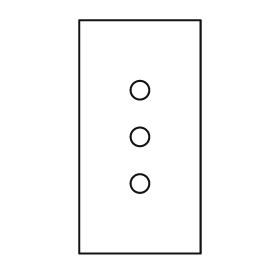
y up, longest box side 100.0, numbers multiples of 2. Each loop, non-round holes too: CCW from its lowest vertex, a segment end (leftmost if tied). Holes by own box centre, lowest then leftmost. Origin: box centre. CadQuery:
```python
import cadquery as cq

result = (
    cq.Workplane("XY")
    .moveTo(-26.0, -50.0)
    .lineTo(26.0, -50.0)
    .lineTo(26.0, 50.0)
    .lineTo(-26.0, 50.0)
    .close()
    .moveTo(0.0, -20.0)
    .circle(4.0)
    .moveTo(0.0, 0.0)
    .circle(4.0)
    .moveTo(0.0, 20.0)
    .circle(4.0)
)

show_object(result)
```